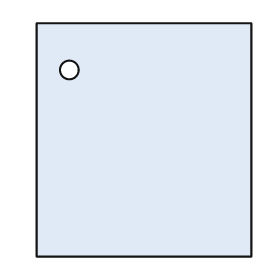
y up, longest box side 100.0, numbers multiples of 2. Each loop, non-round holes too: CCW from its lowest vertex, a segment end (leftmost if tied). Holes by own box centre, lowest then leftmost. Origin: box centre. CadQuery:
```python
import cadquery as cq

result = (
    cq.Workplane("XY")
    .moveTo(-46.0, -50.0)
    .lineTo(46.0, -50.0)
    .lineTo(46.0, 50.0)
    .lineTo(-46.0, 50.0)
    .close()
    .moveTo(-32.0, 30.0)
    .circle(4.0)
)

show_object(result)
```